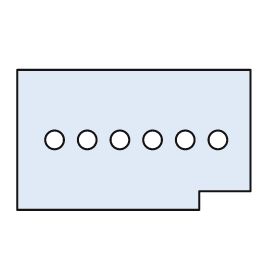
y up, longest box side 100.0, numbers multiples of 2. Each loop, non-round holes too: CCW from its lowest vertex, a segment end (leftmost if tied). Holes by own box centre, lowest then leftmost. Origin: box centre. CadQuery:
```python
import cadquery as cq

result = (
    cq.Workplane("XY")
    .moveTo(-50.0, -30.0)
    .lineTo(28.0, -30.0)
    .lineTo(28.0, -22.0)
    .lineTo(50.0, -22.0)
    .lineTo(50.0, 30.0)
    .lineTo(-50.0, 30.0)
    .close()
    .moveTo(-34.0, 0.0)
    .circle(4.0)
    .moveTo(-20.0, 0.0)
    .circle(4.0)
    .moveTo(-6.0, 0.0)
    .circle(4.0)
    .moveTo(8.0, 0.0)
    .circle(4.0)
    .moveTo(22.0, 0.0)
    .circle(4.0)
    .moveTo(36.0, 0.0)
    .circle(4.0)
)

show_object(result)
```